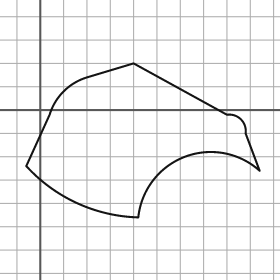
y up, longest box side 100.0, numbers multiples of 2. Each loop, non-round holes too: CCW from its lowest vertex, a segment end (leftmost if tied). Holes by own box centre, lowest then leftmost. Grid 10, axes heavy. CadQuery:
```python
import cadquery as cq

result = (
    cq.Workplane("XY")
    .moveTo(42.0, -46.0)
    .threePointArc((62.0, -20.0), (94.0, -26.0))
    .lineTo(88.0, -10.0)
    .threePointArc((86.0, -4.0), (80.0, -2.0))
    .lineTo(40.0, 20.0)
    .lineTo(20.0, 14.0)
    .threePointArc((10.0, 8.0), (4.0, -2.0))
    .lineTo(-6.0, -24.0)
    .threePointArc((16.0, -40.0), (42.0, -46.0))
    .close()
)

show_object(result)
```